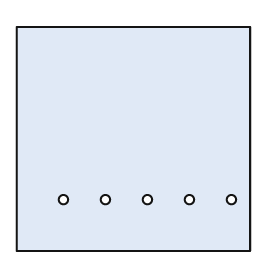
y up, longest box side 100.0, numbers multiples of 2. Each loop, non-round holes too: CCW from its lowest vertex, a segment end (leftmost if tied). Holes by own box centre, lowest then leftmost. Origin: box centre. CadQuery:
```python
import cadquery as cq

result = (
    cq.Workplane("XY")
    .moveTo(-50.0, -48.0)
    .lineTo(50.0, -48.0)
    .lineTo(50.0, 48.0)
    .lineTo(-50.0, 48.0)
    .close()
    .moveTo(-30.0, -26.0)
    .circle(2.0)
    .moveTo(-12.0, -26.0)
    .circle(2.0)
    .moveTo(6.0, -26.0)
    .circle(2.0)
    .moveTo(24.0, -26.0)
    .circle(2.0)
    .moveTo(42.0, -26.0)
    .circle(2.0)
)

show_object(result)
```